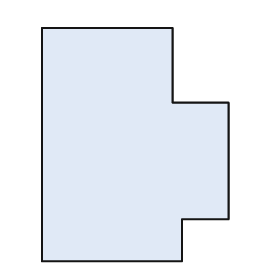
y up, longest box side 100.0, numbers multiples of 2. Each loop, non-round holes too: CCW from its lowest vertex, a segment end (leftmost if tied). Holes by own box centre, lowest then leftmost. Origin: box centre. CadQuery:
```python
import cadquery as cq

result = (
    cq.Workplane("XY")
    .moveTo(-40.0, -50.0)
    .lineTo(20.0, -50.0)
    .lineTo(20.0, -32.0)
    .lineTo(40.0, -32.0)
    .lineTo(40.0, 18.0)
    .lineTo(16.0, 18.0)
    .lineTo(16.0, 50.0)
    .lineTo(-40.0, 50.0)
    .close()
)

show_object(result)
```